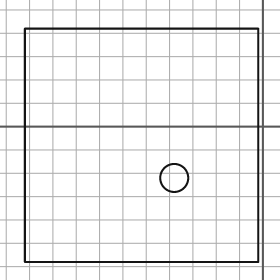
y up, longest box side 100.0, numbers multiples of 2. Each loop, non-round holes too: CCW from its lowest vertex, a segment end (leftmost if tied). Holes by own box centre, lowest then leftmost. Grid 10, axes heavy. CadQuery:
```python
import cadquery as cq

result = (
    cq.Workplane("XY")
    .moveTo(-102.0, -58.0)
    .lineTo(-2.0, -58.0)
    .lineTo(-2.0, 42.0)
    .lineTo(-102.0, 42.0)
    .close()
    .moveTo(-38.0, -22.0)
    .circle(6.0)
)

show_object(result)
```